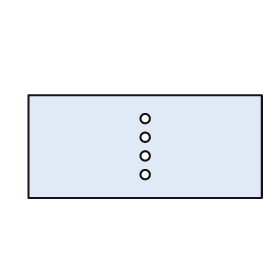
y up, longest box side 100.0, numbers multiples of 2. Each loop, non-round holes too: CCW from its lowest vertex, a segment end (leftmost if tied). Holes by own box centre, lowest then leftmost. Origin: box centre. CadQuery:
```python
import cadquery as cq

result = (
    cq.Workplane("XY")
    .moveTo(-50.0, -22.0)
    .lineTo(50.0, -22.0)
    .lineTo(50.0, 22.0)
    .lineTo(-50.0, 22.0)
    .close()
    .moveTo(0.0, -12.0)
    .circle(2.0)
    .moveTo(0.0, -4.0)
    .circle(2.0)
    .moveTo(0.0, 4.0)
    .circle(2.0)
    .moveTo(0.0, 12.0)
    .circle(2.0)
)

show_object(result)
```